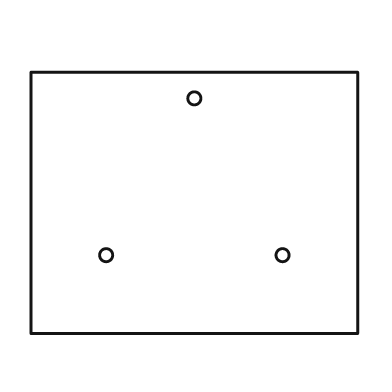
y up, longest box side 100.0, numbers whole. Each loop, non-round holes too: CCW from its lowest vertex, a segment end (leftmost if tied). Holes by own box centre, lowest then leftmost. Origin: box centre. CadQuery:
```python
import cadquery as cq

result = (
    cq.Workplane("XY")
    .moveTo(-50.0, -40.0)
    .lineTo(50.0, -40.0)
    .lineTo(50.0, 40.0)
    .lineTo(-50.0, 40.0)
    .close()
    .moveTo(-27.0, -16.0)
    .circle(2.0)
    .moveTo(27.0, -16.0)
    .circle(2.0)
    .moveTo(0.0, 32.0)
    .circle(2.0)
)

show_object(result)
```